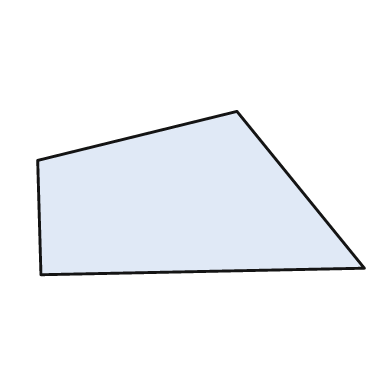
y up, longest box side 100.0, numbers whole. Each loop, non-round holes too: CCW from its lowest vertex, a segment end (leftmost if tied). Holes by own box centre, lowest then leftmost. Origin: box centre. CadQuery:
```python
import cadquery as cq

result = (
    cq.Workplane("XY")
    .moveTo(-49.0, -25.0)
    .lineTo(50.0, -23.0)
    .lineTo(11.0, 25.0)
    .lineTo(-50.0, 10.0)
    .close()
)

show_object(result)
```